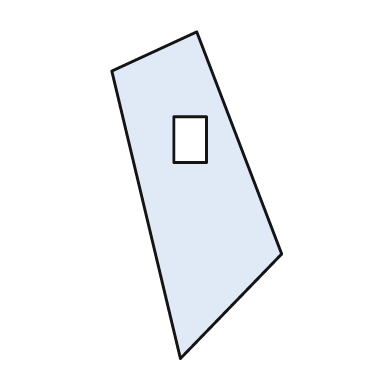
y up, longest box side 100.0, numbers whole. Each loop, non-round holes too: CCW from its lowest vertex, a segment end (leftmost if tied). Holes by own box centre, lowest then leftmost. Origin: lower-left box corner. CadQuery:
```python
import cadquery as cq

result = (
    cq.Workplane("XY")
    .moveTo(21.0, 0.0)
    .lineTo(52.0, 32.0)
    .lineTo(26.0, 100.0)
    .lineTo(0.0, 88.0)
    .close()
    .moveTo(19.0, 60.0)
    .lineTo(29.0, 60.0)
    .lineTo(29.0, 74.0)
    .lineTo(19.0, 74.0)
    .close()
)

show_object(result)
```